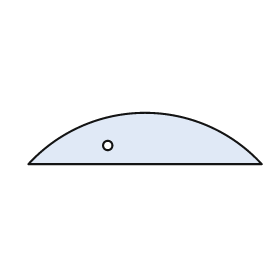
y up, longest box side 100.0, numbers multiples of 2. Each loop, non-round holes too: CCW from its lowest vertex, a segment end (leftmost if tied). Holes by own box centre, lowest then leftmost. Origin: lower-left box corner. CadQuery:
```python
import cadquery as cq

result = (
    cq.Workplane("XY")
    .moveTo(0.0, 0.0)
    .lineTo(100.0, 0.0)
    .threePointArc((50.0, 22.0), (0.0, 0.0))
    .close()
    .moveTo(34.0, 8.0)
    .circle(2.0)
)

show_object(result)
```